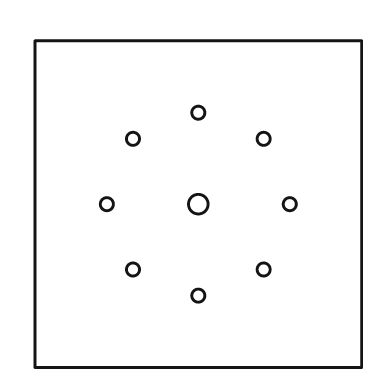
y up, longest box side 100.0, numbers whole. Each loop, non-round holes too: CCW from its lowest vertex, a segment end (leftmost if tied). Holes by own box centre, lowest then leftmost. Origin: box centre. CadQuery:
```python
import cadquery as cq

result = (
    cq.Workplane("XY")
    .moveTo(-50.0, -50.0)
    .lineTo(50.0, -50.0)
    .lineTo(50.0, 50.0)
    .lineTo(-50.0, 50.0)
    .close()
    .moveTo(0.0, -28.0)
    .circle(2.0)
    .moveTo(-20.0, -20.0)
    .circle(2.0)
    .moveTo(20.0, -20.0)
    .circle(2.0)
    .moveTo(-28.0, 0.0)
    .circle(2.0)
    .moveTo(0.0, 0.0)
    .circle(3.0)
    .moveTo(28.0, 0.0)
    .circle(2.0)
    .moveTo(-20.0, 20.0)
    .circle(2.0)
    .moveTo(20.0, 20.0)
    .circle(2.0)
    .moveTo(0.0, 28.0)
    .circle(2.0)
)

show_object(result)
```